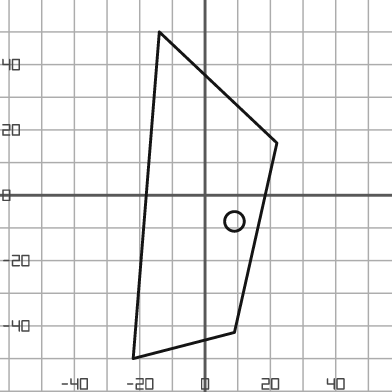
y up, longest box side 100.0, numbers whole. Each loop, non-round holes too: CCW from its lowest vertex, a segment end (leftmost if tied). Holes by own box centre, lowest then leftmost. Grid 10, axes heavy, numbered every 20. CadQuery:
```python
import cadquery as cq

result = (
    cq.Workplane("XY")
    .moveTo(-22.0, -50.0)
    .lineTo(9.0, -42.0)
    .lineTo(22.0, 16.0)
    .lineTo(-14.0, 50.0)
    .close()
    .moveTo(9.0, -8.0)
    .circle(3.0)
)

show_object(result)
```